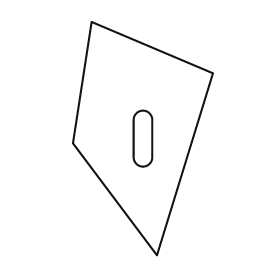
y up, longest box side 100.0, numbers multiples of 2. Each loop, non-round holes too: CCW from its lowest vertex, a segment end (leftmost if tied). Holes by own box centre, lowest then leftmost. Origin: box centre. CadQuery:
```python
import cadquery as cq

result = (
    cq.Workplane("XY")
    .moveTo(6.0, -50.0)
    .lineTo(30.0, 28.0)
    .lineTo(-22.0, 50.0)
    .lineTo(-30.0, -2.0)
    .close()
    .moveTo(-4.0, -8.0)
    .threePointArc((0.0, -12.0), (4.0, -8.0))
    .lineTo(4.0, 8.0)
    .threePointArc((0.0, 12.0), (-4.0, 8.0))
    .close()
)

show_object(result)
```